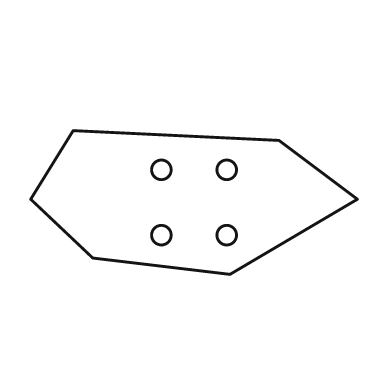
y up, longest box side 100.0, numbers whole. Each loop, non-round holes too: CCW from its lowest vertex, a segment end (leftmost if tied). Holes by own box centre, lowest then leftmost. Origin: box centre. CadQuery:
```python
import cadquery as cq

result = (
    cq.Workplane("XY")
    .moveTo(11.0, -22.0)
    .lineTo(50.0, 1.0)
    .lineTo(26.0, 19.0)
    .lineTo(-37.0, 22.0)
    .lineTo(-50.0, 1.0)
    .lineTo(-31.0, -17.0)
    .close()
    .moveTo(-10.0, -10.0)
    .circle(3.0)
    .moveTo(10.0, -10.0)
    .circle(3.0)
    .moveTo(-10.0, 10.0)
    .circle(3.0)
    .moveTo(10.0, 10.0)
    .circle(3.0)
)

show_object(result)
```